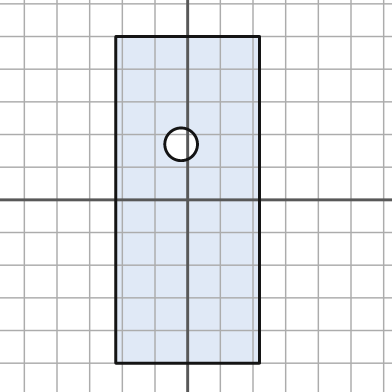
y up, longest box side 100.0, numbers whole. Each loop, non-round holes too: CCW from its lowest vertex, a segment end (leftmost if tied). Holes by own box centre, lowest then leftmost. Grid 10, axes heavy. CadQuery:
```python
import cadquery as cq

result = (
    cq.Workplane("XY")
    .moveTo(-22.0, -50.0)
    .lineTo(22.0, -50.0)
    .lineTo(22.0, 50.0)
    .lineTo(-22.0, 50.0)
    .close()
    .moveTo(-2.0, 17.0)
    .circle(5.0)
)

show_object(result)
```